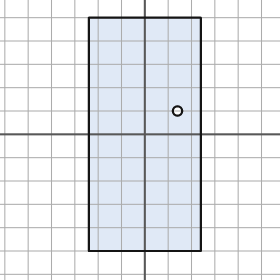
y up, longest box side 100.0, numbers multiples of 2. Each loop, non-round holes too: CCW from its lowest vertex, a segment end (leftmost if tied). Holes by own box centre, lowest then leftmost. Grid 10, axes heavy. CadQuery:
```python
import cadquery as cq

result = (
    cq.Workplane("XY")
    .moveTo(-24.0, -50.0)
    .lineTo(24.0, -50.0)
    .lineTo(24.0, 50.0)
    .lineTo(-24.0, 50.0)
    .close()
    .moveTo(14.0, 10.0)
    .circle(2.0)
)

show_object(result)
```